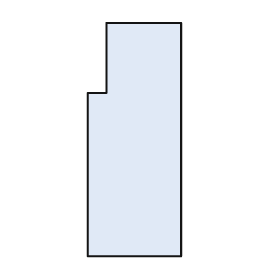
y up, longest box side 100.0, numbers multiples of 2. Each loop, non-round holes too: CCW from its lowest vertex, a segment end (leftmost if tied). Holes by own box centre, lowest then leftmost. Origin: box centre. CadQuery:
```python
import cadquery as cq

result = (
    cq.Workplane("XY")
    .moveTo(-20.0, -50.0)
    .lineTo(20.0, -50.0)
    .lineTo(20.0, 50.0)
    .lineTo(-12.0, 50.0)
    .lineTo(-12.0, 20.0)
    .lineTo(-20.0, 20.0)
    .close()
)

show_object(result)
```